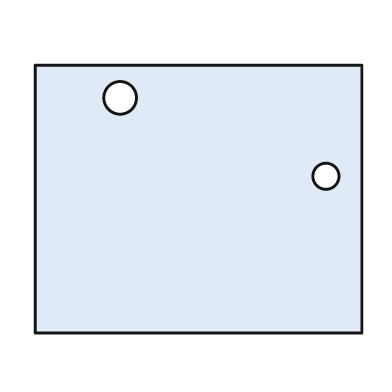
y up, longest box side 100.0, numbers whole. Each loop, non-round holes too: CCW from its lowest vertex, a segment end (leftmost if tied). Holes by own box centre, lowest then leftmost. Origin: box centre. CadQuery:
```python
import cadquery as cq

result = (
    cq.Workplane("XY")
    .moveTo(-50.0, -41.0)
    .lineTo(50.0, -41.0)
    .lineTo(50.0, 41.0)
    .lineTo(-50.0, 41.0)
    .close()
    .moveTo(39.0, 7.0)
    .circle(4.0)
    .moveTo(-24.0, 31.0)
    .circle(5.0)
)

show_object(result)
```